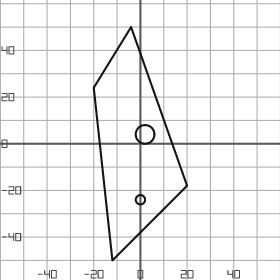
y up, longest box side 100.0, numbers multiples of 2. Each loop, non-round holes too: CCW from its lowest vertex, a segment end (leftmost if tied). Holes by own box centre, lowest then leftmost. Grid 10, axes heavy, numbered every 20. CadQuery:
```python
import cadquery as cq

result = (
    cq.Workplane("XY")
    .moveTo(-12.0, -50.0)
    .lineTo(20.0, -18.0)
    .lineTo(-4.0, 50.0)
    .lineTo(-20.0, 24.0)
    .close()
    .moveTo(0.0, -24.0)
    .circle(2.0)
    .moveTo(2.0, 4.0)
    .circle(4.0)
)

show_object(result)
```